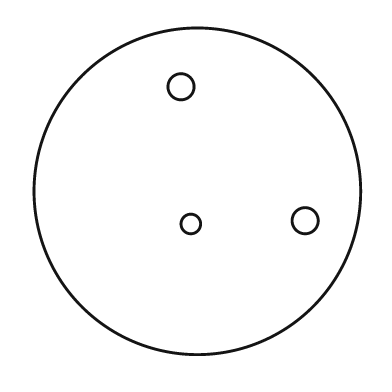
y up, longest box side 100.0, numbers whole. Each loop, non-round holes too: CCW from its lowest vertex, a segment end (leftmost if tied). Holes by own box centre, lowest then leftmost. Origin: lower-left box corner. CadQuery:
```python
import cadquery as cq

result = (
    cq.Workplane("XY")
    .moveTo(50.0, 50.0)
    .circle(50.0)
    .moveTo(48.0, 40.0)
    .circle(3.0)
    .moveTo(83.0, 41.0)
    .circle(4.0)
    .moveTo(45.0, 82.0)
    .circle(4.0)
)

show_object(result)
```